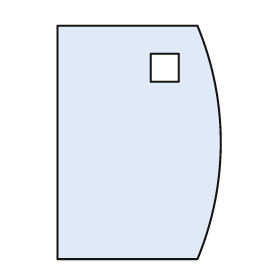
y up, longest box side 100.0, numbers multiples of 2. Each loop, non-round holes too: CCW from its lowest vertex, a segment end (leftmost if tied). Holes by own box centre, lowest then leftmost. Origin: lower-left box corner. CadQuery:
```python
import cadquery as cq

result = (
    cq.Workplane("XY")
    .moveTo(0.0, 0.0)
    .lineTo(60.0, 0.0)
    .threePointArc((70.0, 50.0), (60.0, 100.0))
    .lineTo(0.0, 100.0)
    .close()
    .moveTo(40.0, 76.0)
    .lineTo(52.0, 76.0)
    .lineTo(52.0, 88.0)
    .lineTo(40.0, 88.0)
    .close()
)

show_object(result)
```